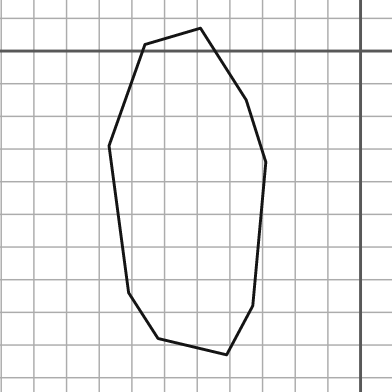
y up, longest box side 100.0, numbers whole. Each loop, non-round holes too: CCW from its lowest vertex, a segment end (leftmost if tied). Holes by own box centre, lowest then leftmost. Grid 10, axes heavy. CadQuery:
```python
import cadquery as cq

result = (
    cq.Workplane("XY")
    .moveTo(-41.0, -93.0)
    .lineTo(-33.0, -78.0)
    .lineTo(-29.0, -34.0)
    .lineTo(-35.0, -15.0)
    .lineTo(-49.0, 7.0)
    .lineTo(-66.0, 2.0)
    .lineTo(-77.0, -29.0)
    .lineTo(-71.0, -74.0)
    .lineTo(-62.0, -88.0)
    .close()
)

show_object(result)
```